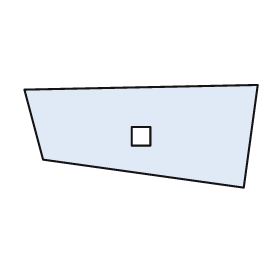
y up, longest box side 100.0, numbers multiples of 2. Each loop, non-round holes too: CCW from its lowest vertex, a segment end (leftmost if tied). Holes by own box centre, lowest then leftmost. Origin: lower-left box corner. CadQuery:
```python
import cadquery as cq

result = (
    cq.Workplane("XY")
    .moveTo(94.0, 0.0)
    .lineTo(100.0, 44.0)
    .lineTo(0.0, 42.0)
    .lineTo(8.0, 12.0)
    .close()
    .moveTo(46.0, 18.0)
    .lineTo(54.0, 18.0)
    .lineTo(54.0, 26.0)
    .lineTo(46.0, 26.0)
    .close()
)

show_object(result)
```